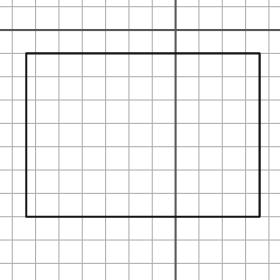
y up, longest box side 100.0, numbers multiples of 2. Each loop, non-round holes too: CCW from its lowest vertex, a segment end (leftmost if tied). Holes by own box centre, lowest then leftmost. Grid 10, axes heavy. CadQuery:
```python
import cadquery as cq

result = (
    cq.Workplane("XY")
    .moveTo(-64.0, -80.0)
    .lineTo(36.0, -80.0)
    .lineTo(36.0, -10.0)
    .lineTo(-64.0, -10.0)
    .close()
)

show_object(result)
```